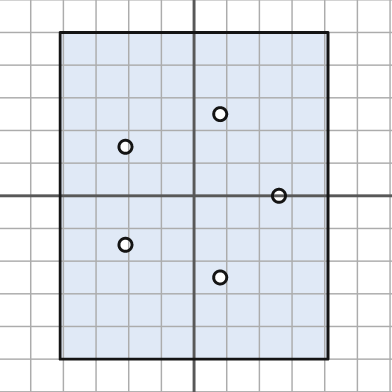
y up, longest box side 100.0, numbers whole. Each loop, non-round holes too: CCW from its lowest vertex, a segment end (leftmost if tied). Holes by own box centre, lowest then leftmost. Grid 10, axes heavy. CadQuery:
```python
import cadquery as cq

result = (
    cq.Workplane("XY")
    .moveTo(-41.0, -50.0)
    .lineTo(41.0, -50.0)
    .lineTo(41.0, 50.0)
    .lineTo(-41.0, 50.0)
    .close()
    .moveTo(8.0, -25.0)
    .circle(2.0)
    .moveTo(-21.0, -15.0)
    .circle(2.0)
    .moveTo(26.0, 0.0)
    .circle(2.0)
    .moveTo(-21.0, 15.0)
    .circle(2.0)
    .moveTo(8.0, 25.0)
    .circle(2.0)
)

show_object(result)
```